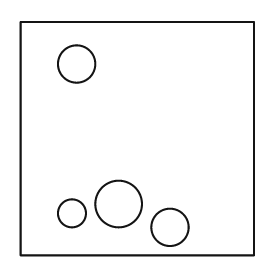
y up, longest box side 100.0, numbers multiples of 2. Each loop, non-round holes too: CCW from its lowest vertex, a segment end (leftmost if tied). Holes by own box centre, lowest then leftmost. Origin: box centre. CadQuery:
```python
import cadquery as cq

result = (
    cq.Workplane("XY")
    .moveTo(-50.0, -50.0)
    .lineTo(50.0, -50.0)
    .lineTo(50.0, 50.0)
    .lineTo(-50.0, 50.0)
    .close()
    .moveTo(14.0, -38.0)
    .circle(8.0)
    .moveTo(-28.0, -32.0)
    .circle(6.0)
    .moveTo(-8.0, -28.0)
    .circle(10.0)
    .moveTo(-26.0, 32.0)
    .circle(8.0)
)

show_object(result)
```